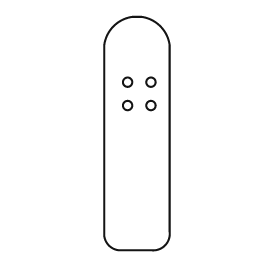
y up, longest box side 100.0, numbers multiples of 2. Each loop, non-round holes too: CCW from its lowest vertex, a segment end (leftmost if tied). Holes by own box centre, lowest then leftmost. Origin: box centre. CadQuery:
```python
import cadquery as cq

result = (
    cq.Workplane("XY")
    .moveTo(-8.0, -50.0)
    .lineTo(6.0, -50.0)
    .threePointArc((12.0, -48.0), (14.0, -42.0))
    .lineTo(14.0, 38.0)
    .threePointArc((10.0, 46.0), (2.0, 50.0))
    .lineTo(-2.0, 50.0)
    .threePointArc((-10.0, 46.0), (-14.0, 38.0))
    .lineTo(-14.0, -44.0)
    .threePointArc((-12.0, -48.0), (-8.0, -50.0))
    .close()
    .moveTo(-4.0, 12.0)
    .circle(2.0)
    .moveTo(6.0, 12.0)
    .circle(2.0)
    .moveTo(-4.0, 22.0)
    .circle(2.0)
    .moveTo(6.0, 22.0)
    .circle(2.0)
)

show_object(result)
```